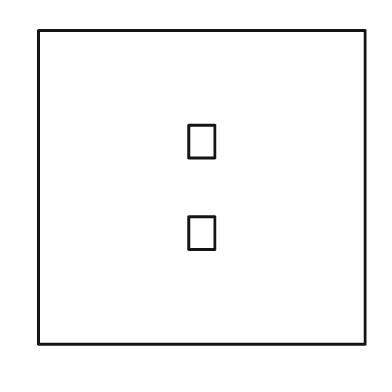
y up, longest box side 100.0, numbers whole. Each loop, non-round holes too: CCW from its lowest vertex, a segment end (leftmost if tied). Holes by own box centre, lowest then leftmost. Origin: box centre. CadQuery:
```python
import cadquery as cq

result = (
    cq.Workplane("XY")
    .moveTo(-50.0, -48.0)
    .lineTo(50.0, -48.0)
    .lineTo(50.0, 48.0)
    .lineTo(-50.0, 48.0)
    .close()
    .moveTo(-4.0, -19.0)
    .lineTo(4.0, -19.0)
    .lineTo(4.0, -9.0)
    .lineTo(-4.0, -9.0)
    .close()
    .moveTo(-4.0, 9.0)
    .lineTo(4.0, 9.0)
    .lineTo(4.0, 19.0)
    .lineTo(-4.0, 19.0)
    .close()
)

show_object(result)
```